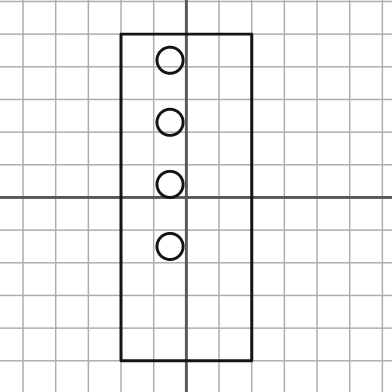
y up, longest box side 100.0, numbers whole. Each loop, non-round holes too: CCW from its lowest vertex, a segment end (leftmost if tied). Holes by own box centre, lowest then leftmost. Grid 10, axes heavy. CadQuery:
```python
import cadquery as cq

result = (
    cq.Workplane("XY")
    .moveTo(-20.0, -50.0)
    .lineTo(20.0, -50.0)
    .lineTo(20.0, 50.0)
    .lineTo(-20.0, 50.0)
    .close()
    .moveTo(-5.0, -15.0)
    .circle(4.0)
    .moveTo(-5.0, 4.0)
    .circle(4.0)
    .moveTo(-5.0, 23.0)
    .circle(4.0)
    .moveTo(-5.0, 42.0)
    .circle(4.0)
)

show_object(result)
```